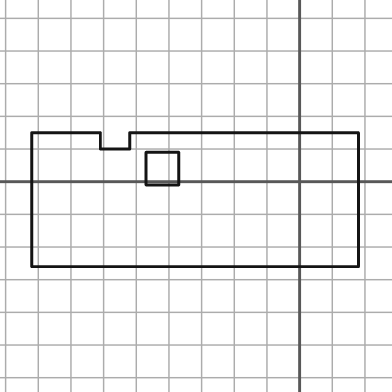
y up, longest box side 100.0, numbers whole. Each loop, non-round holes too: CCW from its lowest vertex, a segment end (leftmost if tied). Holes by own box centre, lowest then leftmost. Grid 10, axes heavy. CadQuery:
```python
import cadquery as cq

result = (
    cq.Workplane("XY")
    .moveTo(-82.0, -26.0)
    .lineTo(18.0, -26.0)
    .lineTo(18.0, 15.0)
    .lineTo(-52.0, 15.0)
    .lineTo(-52.0, 10.0)
    .lineTo(-61.0, 10.0)
    .lineTo(-61.0, 15.0)
    .lineTo(-82.0, 15.0)
    .close()
    .moveTo(-47.0, -1.0)
    .lineTo(-37.0, -1.0)
    .lineTo(-37.0, 9.0)
    .lineTo(-47.0, 9.0)
    .close()
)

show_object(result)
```